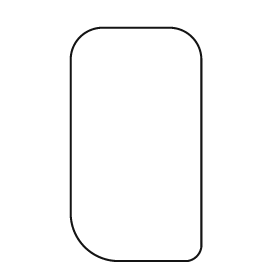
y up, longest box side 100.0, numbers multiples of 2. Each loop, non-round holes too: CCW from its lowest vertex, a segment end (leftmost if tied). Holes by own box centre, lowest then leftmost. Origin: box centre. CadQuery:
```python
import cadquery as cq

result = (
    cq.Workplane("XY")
    .moveTo(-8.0, -50.0)
    .lineTo(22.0, -50.0)
    .threePointArc((26.0, -48.0), (28.0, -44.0))
    .lineTo(28.0, 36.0)
    .threePointArc((24.0, 46.0), (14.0, 50.0))
    .lineTo(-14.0, 50.0)
    .threePointArc((-24.0, 46.0), (-28.0, 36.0))
    .lineTo(-28.0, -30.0)
    .threePointArc((-22.0, -44.0), (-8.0, -50.0))
    .close()
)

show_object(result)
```